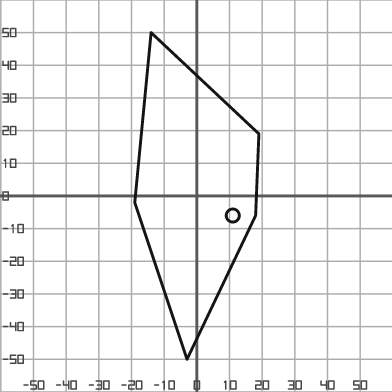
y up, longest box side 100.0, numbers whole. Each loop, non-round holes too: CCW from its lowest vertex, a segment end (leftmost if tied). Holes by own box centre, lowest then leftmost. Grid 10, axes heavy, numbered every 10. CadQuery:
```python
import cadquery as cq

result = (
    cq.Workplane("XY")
    .moveTo(-3.0, -50.0)
    .lineTo(18.0, -6.0)
    .lineTo(19.0, 19.0)
    .lineTo(-14.0, 50.0)
    .lineTo(-19.0, -2.0)
    .close()
    .moveTo(11.0, -6.0)
    .circle(2.0)
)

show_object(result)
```